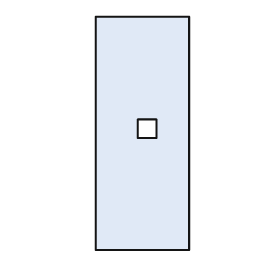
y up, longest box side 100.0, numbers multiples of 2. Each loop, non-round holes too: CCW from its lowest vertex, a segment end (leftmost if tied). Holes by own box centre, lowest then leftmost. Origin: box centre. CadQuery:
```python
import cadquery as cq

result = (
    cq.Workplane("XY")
    .moveTo(-20.0, -50.0)
    .lineTo(20.0, -50.0)
    .lineTo(20.0, 50.0)
    .lineTo(-20.0, 50.0)
    .close()
    .moveTo(-2.0, -2.0)
    .lineTo(6.0, -2.0)
    .lineTo(6.0, 6.0)
    .lineTo(-2.0, 6.0)
    .close()
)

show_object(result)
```